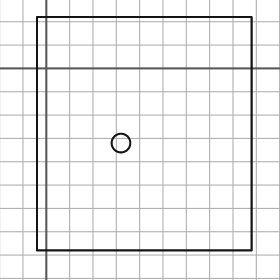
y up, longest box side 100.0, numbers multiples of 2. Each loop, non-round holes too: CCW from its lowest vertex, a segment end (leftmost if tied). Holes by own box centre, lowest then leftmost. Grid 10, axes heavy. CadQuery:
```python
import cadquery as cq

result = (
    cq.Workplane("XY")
    .moveTo(-4.0, -78.0)
    .lineTo(88.0, -78.0)
    .lineTo(88.0, 22.0)
    .lineTo(-4.0, 22.0)
    .close()
    .moveTo(32.0, -32.0)
    .circle(4.0)
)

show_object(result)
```